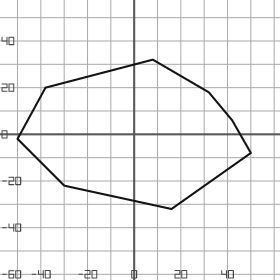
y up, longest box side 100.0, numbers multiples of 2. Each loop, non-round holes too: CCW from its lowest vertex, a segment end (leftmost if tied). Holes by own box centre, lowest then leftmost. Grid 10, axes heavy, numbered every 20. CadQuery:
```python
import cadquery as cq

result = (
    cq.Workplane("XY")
    .moveTo(16.0, -32.0)
    .lineTo(50.0, -8.0)
    .lineTo(42.0, 6.0)
    .lineTo(32.0, 18.0)
    .lineTo(8.0, 32.0)
    .lineTo(-38.0, 20.0)
    .lineTo(-50.0, -2.0)
    .lineTo(-30.0, -22.0)
    .close()
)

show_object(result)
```